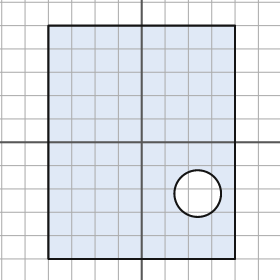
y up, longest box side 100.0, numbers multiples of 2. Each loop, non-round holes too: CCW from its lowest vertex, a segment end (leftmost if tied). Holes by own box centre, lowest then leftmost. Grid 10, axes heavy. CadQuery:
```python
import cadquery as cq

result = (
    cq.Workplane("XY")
    .moveTo(-40.0, -50.0)
    .lineTo(40.0, -50.0)
    .lineTo(40.0, 50.0)
    .lineTo(-40.0, 50.0)
    .close()
    .moveTo(24.0, -22.0)
    .circle(10.0)
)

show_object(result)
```